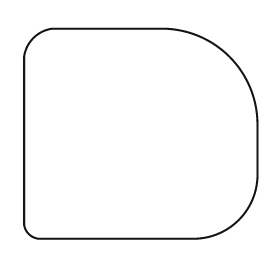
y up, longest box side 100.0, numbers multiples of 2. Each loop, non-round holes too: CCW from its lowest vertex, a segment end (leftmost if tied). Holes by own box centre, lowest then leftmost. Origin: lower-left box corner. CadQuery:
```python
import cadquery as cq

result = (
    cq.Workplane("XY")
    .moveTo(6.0, 0.0)
    .lineTo(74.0, 0.0)
    .threePointArc((92.0, 8.0), (100.0, 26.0))
    .lineTo(100.0, 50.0)
    .threePointArc((88.0, 78.0), (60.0, 90.0))
    .lineTo(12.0, 90.0)
    .threePointArc((4.0, 86.0), (0.0, 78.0))
    .lineTo(0.0, 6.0)
    .threePointArc((2.0, 2.0), (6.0, 0.0))
    .close()
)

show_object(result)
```